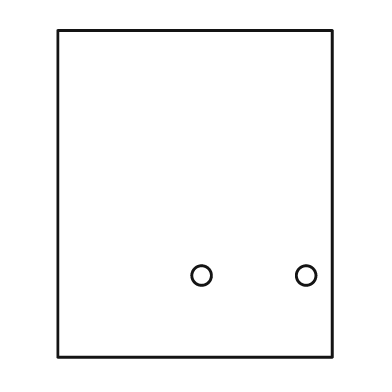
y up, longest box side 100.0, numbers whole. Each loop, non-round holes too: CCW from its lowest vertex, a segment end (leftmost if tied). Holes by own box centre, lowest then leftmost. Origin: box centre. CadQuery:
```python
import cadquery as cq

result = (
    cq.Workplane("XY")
    .moveTo(-42.0, -50.0)
    .lineTo(42.0, -50.0)
    .lineTo(42.0, 50.0)
    .lineTo(-42.0, 50.0)
    .close()
    .moveTo(2.0, -25.0)
    .circle(3.0)
    .moveTo(34.0, -25.0)
    .circle(3.0)
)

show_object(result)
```